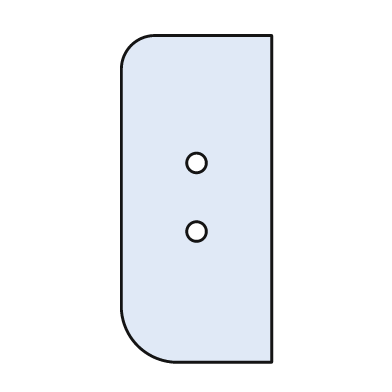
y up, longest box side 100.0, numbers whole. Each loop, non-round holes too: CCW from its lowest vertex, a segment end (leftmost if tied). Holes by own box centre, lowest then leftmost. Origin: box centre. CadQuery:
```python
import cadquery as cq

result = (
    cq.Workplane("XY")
    .moveTo(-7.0, -50.0)
    .lineTo(23.0, -50.0)
    .lineTo(23.0, 50.0)
    .lineTo(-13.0, 50.0)
    .threePointArc((-20.0, 47.0), (-23.0, 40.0))
    .lineTo(-23.0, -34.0)
    .threePointArc((-18.0, -45.0), (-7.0, -50.0))
    .close()
    .moveTo(0.0, -10.0)
    .circle(3.0)
    .moveTo(0.0, 11.0)
    .circle(3.0)
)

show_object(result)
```